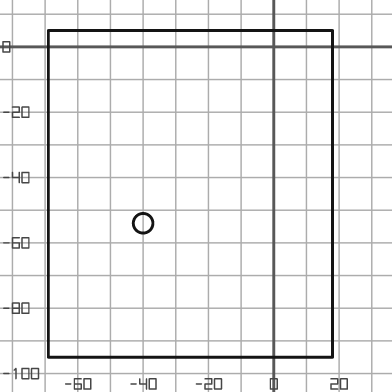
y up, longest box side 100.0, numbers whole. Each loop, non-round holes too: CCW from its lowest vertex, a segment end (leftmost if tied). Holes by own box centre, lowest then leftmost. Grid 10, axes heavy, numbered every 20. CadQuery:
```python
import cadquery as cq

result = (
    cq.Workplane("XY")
    .moveTo(-69.0, -95.0)
    .lineTo(18.0, -95.0)
    .lineTo(18.0, 5.0)
    .lineTo(-69.0, 5.0)
    .close()
    .moveTo(-40.0, -54.0)
    .circle(3.0)
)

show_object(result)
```